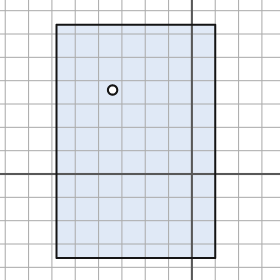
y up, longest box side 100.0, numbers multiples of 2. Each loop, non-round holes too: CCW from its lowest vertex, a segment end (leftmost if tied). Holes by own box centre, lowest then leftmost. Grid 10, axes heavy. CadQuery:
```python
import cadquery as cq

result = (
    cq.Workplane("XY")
    .moveTo(-58.0, -36.0)
    .lineTo(10.0, -36.0)
    .lineTo(10.0, 64.0)
    .lineTo(-58.0, 64.0)
    .close()
    .moveTo(-34.0, 36.0)
    .circle(2.0)
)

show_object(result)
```